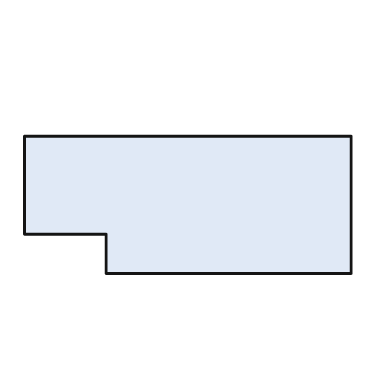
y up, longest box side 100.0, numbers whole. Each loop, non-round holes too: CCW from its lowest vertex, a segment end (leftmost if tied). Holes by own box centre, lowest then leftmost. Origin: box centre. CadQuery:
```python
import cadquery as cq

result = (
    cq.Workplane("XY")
    .moveTo(-25.0, -21.0)
    .lineTo(50.0, -21.0)
    .lineTo(50.0, 21.0)
    .lineTo(-50.0, 21.0)
    .lineTo(-50.0, -9.0)
    .lineTo(-25.0, -9.0)
    .close()
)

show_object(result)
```